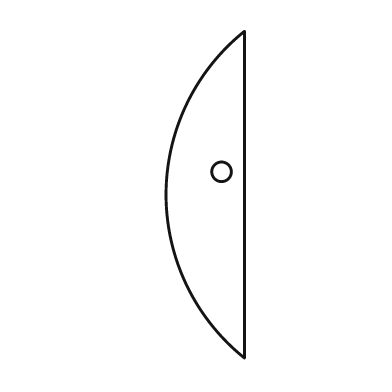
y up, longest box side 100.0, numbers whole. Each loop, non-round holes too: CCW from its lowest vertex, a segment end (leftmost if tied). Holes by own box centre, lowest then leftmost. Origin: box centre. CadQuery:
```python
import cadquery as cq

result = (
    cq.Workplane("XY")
    .moveTo(12.0, -50.0)
    .lineTo(12.0, 50.0)
    .threePointArc((-12.0, 0.0), (12.0, -50.0))
    .close()
    .moveTo(5.0, 7.0)
    .circle(3.0)
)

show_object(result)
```